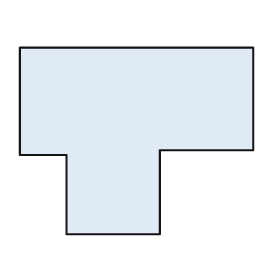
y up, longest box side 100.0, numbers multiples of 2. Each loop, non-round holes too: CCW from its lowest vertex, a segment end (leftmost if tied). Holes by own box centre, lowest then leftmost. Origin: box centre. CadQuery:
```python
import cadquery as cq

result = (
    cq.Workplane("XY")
    .moveTo(-30.0, -40.0)
    .lineTo(10.0, -40.0)
    .lineTo(10.0, -4.0)
    .lineTo(50.0, -4.0)
    .lineTo(50.0, 40.0)
    .lineTo(-50.0, 40.0)
    .lineTo(-50.0, -6.0)
    .lineTo(-30.0, -6.0)
    .close()
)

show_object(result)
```